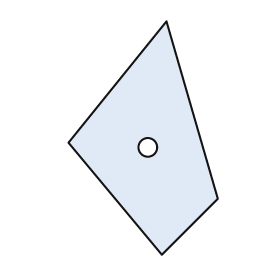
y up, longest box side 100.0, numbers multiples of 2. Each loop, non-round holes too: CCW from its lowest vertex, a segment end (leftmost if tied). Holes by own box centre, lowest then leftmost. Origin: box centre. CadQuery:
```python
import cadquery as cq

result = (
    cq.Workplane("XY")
    .moveTo(8.0, -50.0)
    .lineTo(32.0, -26.0)
    .lineTo(10.0, 50.0)
    .lineTo(-32.0, -2.0)
    .close()
    .moveTo(2.0, -4.0)
    .circle(4.0)
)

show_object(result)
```